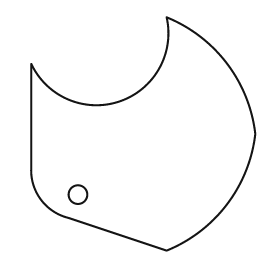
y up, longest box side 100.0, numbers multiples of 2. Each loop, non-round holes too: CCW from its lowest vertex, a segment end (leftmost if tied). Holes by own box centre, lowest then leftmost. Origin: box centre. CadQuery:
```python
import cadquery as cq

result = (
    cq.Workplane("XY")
    .moveTo(10.0, -50.0)
    .threePointArc((36.0, -30.0), (48.0, 0.0))
    .threePointArc((36.0, 30.0), (10.0, 50.0))
    .threePointArc((-10.0, 14.0), (-48.0, 30.0))
    .lineTo(-48.0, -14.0)
    .threePointArc((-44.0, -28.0), (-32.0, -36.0))
    .close()
    .moveTo(-28.0, -26.0)
    .circle(4.0)
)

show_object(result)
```